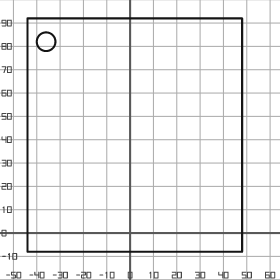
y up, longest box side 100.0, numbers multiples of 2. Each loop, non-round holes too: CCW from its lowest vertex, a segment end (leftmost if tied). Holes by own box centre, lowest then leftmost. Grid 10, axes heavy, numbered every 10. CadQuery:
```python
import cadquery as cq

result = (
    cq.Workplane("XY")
    .moveTo(-44.0, -8.0)
    .lineTo(48.0, -8.0)
    .lineTo(48.0, 92.0)
    .lineTo(-44.0, 92.0)
    .close()
    .moveTo(-36.0, 82.0)
    .circle(4.0)
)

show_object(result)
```